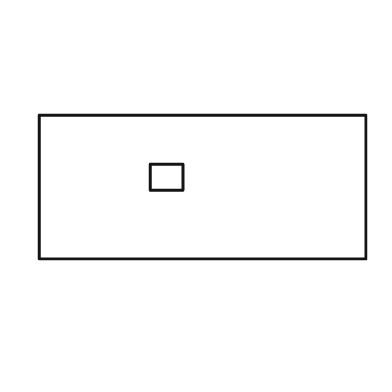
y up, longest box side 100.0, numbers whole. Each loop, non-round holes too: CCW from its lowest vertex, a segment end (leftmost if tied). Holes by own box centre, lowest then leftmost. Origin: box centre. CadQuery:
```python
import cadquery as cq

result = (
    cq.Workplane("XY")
    .moveTo(-50.0, -22.0)
    .lineTo(50.0, -22.0)
    .lineTo(50.0, 22.0)
    .lineTo(-50.0, 22.0)
    .close()
    .moveTo(-16.0, -1.0)
    .lineTo(-6.0, -1.0)
    .lineTo(-6.0, 7.0)
    .lineTo(-16.0, 7.0)
    .close()
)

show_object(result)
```